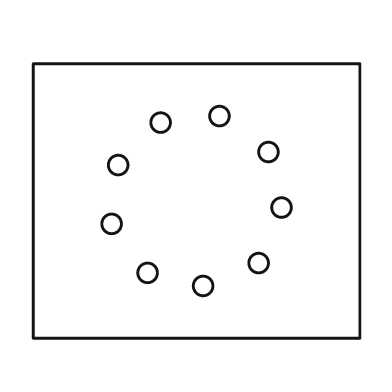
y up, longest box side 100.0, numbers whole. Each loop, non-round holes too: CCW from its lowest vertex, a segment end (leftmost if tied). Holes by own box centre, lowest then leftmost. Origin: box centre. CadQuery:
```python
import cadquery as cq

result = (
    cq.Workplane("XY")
    .moveTo(-50.0, -42.0)
    .lineTo(50.0, -42.0)
    .lineTo(50.0, 42.0)
    .lineTo(-50.0, 42.0)
    .close()
    .moveTo(2.0, -26.0)
    .circle(3.0)
    .moveTo(-15.0, -22.0)
    .circle(3.0)
    .moveTo(19.0, -19.0)
    .circle(3.0)
    .moveTo(-26.0, -7.0)
    .circle(3.0)
    .moveTo(26.0, -2.0)
    .circle(3.0)
    .moveTo(-24.0, 11.0)
    .circle(3.0)
    .moveTo(22.0, 15.0)
    .circle(3.0)
    .moveTo(-11.0, 24.0)
    .circle(3.0)
    .moveTo(7.0, 26.0)
    .circle(3.0)
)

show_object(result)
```